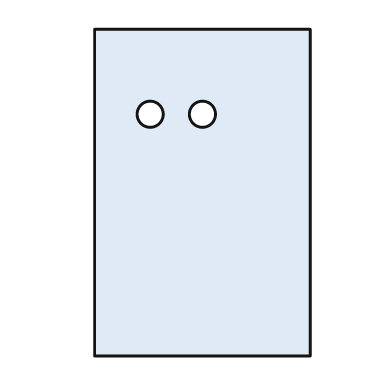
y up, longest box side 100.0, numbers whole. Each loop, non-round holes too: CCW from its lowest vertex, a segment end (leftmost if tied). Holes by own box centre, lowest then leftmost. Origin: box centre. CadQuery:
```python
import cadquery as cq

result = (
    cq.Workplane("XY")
    .moveTo(-33.0, -50.0)
    .lineTo(33.0, -50.0)
    .lineTo(33.0, 50.0)
    .lineTo(-33.0, 50.0)
    .close()
    .moveTo(-16.0, 24.0)
    .circle(4.0)
    .moveTo(0.0, 24.0)
    .circle(4.0)
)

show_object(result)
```